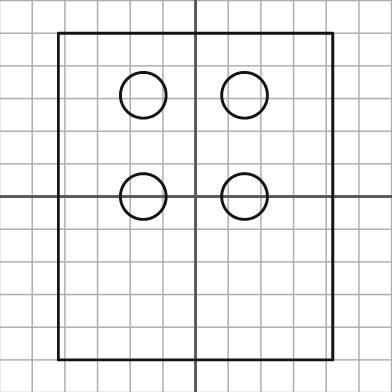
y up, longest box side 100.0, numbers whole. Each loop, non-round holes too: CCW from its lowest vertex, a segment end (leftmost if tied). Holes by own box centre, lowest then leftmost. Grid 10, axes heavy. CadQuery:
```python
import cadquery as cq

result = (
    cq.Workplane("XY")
    .moveTo(-42.0, -50.0)
    .lineTo(42.0, -50.0)
    .lineTo(42.0, 50.0)
    .lineTo(-42.0, 50.0)
    .close()
    .moveTo(-16.0, 0.0)
    .circle(7.0)
    .moveTo(15.0, 0.0)
    .circle(7.0)
    .moveTo(-16.0, 31.0)
    .circle(7.0)
    .moveTo(15.0, 31.0)
    .circle(7.0)
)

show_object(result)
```